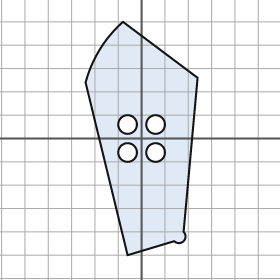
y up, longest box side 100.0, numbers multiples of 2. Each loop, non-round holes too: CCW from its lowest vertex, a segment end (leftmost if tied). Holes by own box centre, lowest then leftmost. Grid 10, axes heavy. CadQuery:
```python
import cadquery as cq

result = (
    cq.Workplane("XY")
    .moveTo(-6.0, -50.0)
    .lineTo(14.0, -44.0)
    .threePointArc((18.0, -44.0), (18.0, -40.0))
    .lineTo(24.0, 26.0)
    .lineTo(-8.0, 50.0)
    .threePointArc((-18.0, 38.0), (-24.0, 24.0))
    .close()
    .moveTo(-6.0, -6.0)
    .circle(4.0)
    .moveTo(6.0, -6.0)
    .circle(4.0)
    .moveTo(-6.0, 6.0)
    .circle(4.0)
    .moveTo(6.0, 6.0)
    .circle(4.0)
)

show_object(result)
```